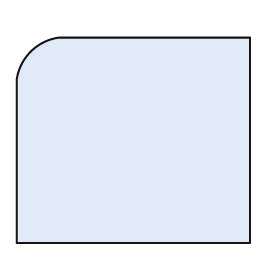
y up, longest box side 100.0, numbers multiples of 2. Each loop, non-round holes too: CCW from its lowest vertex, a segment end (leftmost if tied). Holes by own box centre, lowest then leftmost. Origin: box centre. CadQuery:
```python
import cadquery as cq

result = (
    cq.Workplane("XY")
    .moveTo(-50.0, -44.0)
    .lineTo(50.0, -44.0)
    .lineTo(50.0, 44.0)
    .lineTo(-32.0, 44.0)
    .threePointArc((-44.0, 38.0), (-50.0, 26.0))
    .close()
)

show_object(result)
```